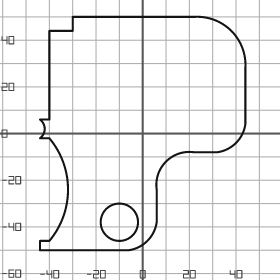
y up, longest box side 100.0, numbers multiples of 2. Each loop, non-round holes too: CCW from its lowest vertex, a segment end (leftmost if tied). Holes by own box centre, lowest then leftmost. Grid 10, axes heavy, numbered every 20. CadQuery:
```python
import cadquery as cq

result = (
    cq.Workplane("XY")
    .moveTo(-44.0, -50.0)
    .lineTo(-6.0, -50.0)
    .threePointArc((2.0, -46.0), (6.0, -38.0))
    .lineTo(6.0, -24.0)
    .threePointArc((10.0, -12.0), (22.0, -8.0))
    .lineTo(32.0, -8.0)
    .threePointArc((40.0, -4.0), (44.0, 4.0))
    .lineTo(44.0, 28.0)
    .threePointArc((38.0, 44.0), (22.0, 50.0))
    .lineTo(-30.0, 50.0)
    .lineTo(-30.0, 44.0)
    .lineTo(-40.0, 44.0)
    .lineTo(-40.0, 6.0)
    .lineTo(-44.0, 6.0)
    .threePointArc((-42.0, 2.0), (-44.0, -2.0))
    .lineTo(-40.0, -2.0)
    .threePointArc((-32.0, -24.0), (-40.0, -46.0))
    .lineTo(-44.0, -46.0)
    .close()
    .moveTo(-10.0, -38.0)
    .circle(8.0)
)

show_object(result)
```